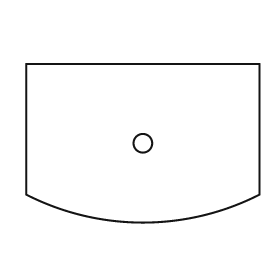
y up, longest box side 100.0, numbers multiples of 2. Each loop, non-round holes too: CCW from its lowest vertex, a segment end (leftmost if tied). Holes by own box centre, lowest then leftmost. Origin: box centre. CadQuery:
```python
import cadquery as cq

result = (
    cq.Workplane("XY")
    .moveTo(-50.0, -22.0)
    .threePointArc((0.0, -34.0), (50.0, -22.0))
    .lineTo(50.0, 34.0)
    .lineTo(-50.0, 34.0)
    .close()
    .moveTo(0.0, 0.0)
    .circle(4.0)
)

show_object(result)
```